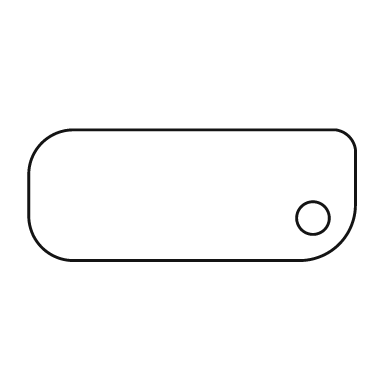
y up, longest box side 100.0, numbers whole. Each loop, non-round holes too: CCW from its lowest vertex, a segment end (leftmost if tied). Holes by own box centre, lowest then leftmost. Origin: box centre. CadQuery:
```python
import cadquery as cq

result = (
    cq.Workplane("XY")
    .moveTo(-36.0, -20.0)
    .lineTo(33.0, -20.0)
    .threePointArc((45.0, -15.0), (50.0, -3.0))
    .lineTo(50.0, 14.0)
    .threePointArc((48.0, 18.0), (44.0, 20.0))
    .lineTo(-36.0, 20.0)
    .threePointArc((-46.0, 16.0), (-50.0, 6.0))
    .lineTo(-50.0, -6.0)
    .threePointArc((-46.0, -16.0), (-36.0, -20.0))
    .close()
    .moveTo(37.0, -7.0)
    .circle(5.0)
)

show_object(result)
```